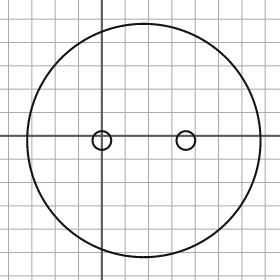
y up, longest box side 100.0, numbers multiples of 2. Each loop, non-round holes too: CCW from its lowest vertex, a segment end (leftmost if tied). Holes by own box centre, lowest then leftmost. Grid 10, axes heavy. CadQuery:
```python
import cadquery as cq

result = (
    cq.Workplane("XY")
    .moveTo(18.0, -2.0)
    .circle(50.0)
    .moveTo(0.0, -2.0)
    .circle(4.0)
    .moveTo(36.0, -2.0)
    .circle(4.0)
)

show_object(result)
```